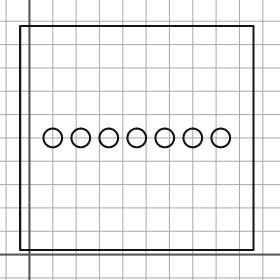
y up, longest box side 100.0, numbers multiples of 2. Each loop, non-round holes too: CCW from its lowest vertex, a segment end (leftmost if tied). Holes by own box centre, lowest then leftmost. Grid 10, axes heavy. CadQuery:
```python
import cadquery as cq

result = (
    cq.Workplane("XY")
    .moveTo(-4.0, 2.0)
    .lineTo(96.0, 2.0)
    .lineTo(96.0, 98.0)
    .lineTo(-4.0, 98.0)
    .close()
    .moveTo(10.0, 50.0)
    .circle(4.0)
    .moveTo(22.0, 50.0)
    .circle(4.0)
    .moveTo(34.0, 50.0)
    .circle(4.0)
    .moveTo(46.0, 50.0)
    .circle(4.0)
    .moveTo(58.0, 50.0)
    .circle(4.0)
    .moveTo(70.0, 50.0)
    .circle(4.0)
    .moveTo(82.0, 50.0)
    .circle(4.0)
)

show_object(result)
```